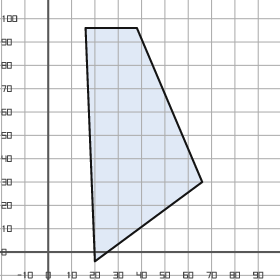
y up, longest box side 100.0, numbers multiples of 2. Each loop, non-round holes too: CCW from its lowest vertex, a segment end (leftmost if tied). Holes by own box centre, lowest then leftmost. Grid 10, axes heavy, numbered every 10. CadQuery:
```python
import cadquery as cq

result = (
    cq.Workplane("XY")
    .moveTo(20.0, -4.0)
    .lineTo(66.0, 30.0)
    .lineTo(38.0, 96.0)
    .lineTo(16.0, 96.0)
    .close()
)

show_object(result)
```